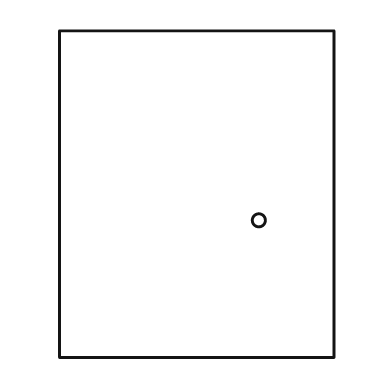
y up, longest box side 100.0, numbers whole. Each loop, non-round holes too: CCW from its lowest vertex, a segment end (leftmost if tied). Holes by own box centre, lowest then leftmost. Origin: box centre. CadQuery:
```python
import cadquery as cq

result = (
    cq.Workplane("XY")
    .moveTo(-42.0, -50.0)
    .lineTo(42.0, -50.0)
    .lineTo(42.0, 50.0)
    .lineTo(-42.0, 50.0)
    .close()
    .moveTo(19.0, -8.0)
    .circle(2.0)
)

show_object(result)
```